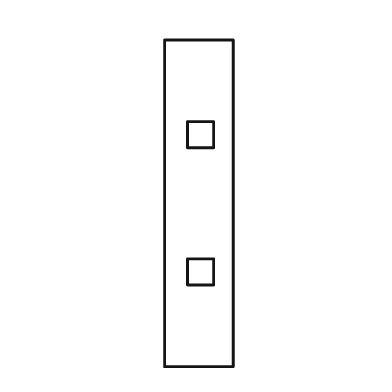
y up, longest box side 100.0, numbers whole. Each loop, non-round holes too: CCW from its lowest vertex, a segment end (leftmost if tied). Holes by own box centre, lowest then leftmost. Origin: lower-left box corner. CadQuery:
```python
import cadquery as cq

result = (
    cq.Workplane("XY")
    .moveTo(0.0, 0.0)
    .lineTo(21.0, 0.0)
    .lineTo(21.0, 100.0)
    .lineTo(0.0, 100.0)
    .close()
    .moveTo(7.0, 25.0)
    .lineTo(15.0, 25.0)
    .lineTo(15.0, 33.0)
    .lineTo(7.0, 33.0)
    .close()
    .moveTo(7.0, 67.0)
    .lineTo(15.0, 67.0)
    .lineTo(15.0, 75.0)
    .lineTo(7.0, 75.0)
    .close()
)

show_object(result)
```